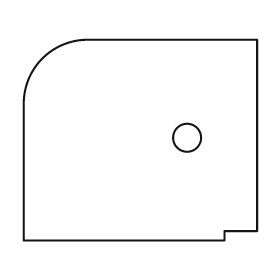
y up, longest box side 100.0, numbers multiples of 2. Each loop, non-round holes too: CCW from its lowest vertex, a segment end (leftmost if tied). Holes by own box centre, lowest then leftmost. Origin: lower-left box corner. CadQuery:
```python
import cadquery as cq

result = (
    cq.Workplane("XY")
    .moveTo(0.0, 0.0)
    .lineTo(86.0, 0.0)
    .lineTo(86.0, 4.0)
    .lineTo(100.0, 4.0)
    .lineTo(100.0, 86.0)
    .lineTo(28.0, 86.0)
    .threePointArc((8.0, 78.0), (0.0, 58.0))
    .close()
    .moveTo(70.0, 44.0)
    .circle(6.0)
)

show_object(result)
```